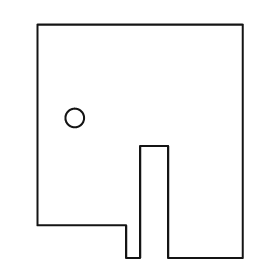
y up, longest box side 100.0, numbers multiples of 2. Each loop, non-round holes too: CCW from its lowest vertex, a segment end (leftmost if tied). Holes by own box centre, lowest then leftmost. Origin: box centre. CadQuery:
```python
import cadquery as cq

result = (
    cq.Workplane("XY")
    .moveTo(-6.0, -50.0)
    .lineTo(0.0, -50.0)
    .lineTo(0.0, -2.0)
    .lineTo(12.0, -2.0)
    .lineTo(12.0, -50.0)
    .lineTo(44.0, -50.0)
    .lineTo(44.0, 50.0)
    .lineTo(-44.0, 50.0)
    .lineTo(-44.0, -36.0)
    .lineTo(-6.0, -36.0)
    .close()
    .moveTo(-28.0, 10.0)
    .circle(4.0)
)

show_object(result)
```